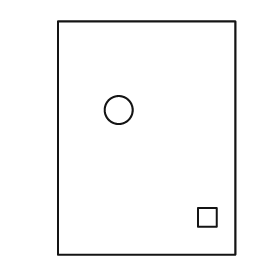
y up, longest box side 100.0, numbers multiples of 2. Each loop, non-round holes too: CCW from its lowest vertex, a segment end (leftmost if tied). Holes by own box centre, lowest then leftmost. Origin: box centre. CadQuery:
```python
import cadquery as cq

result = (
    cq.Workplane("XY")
    .moveTo(-38.0, -50.0)
    .lineTo(38.0, -50.0)
    .lineTo(38.0, 50.0)
    .lineTo(-38.0, 50.0)
    .close()
    .moveTo(22.0, -38.0)
    .lineTo(30.0, -38.0)
    .lineTo(30.0, -30.0)
    .lineTo(22.0, -30.0)
    .close()
    .moveTo(-12.0, 12.0)
    .circle(6.0)
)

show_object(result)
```